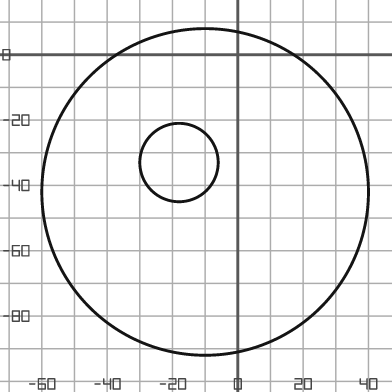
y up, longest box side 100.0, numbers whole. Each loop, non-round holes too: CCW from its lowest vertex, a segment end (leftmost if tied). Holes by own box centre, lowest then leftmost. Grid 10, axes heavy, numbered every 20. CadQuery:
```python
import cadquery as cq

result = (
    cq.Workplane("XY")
    .moveTo(-10.0, -42.0)
    .circle(50.0)
    .moveTo(-18.0, -33.0)
    .circle(12.0)
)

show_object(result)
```